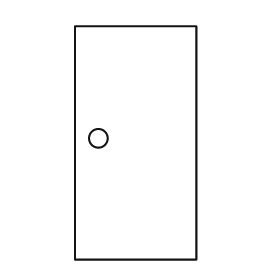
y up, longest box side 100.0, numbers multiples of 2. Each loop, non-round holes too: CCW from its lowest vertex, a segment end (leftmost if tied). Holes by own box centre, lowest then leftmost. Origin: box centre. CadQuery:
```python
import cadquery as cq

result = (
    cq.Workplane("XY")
    .moveTo(-26.0, -50.0)
    .lineTo(26.0, -50.0)
    .lineTo(26.0, 50.0)
    .lineTo(-26.0, 50.0)
    .close()
    .moveTo(-16.0, 2.0)
    .circle(4.0)
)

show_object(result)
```